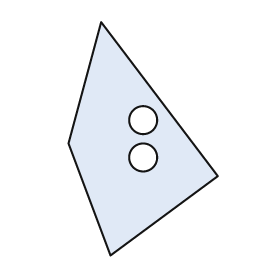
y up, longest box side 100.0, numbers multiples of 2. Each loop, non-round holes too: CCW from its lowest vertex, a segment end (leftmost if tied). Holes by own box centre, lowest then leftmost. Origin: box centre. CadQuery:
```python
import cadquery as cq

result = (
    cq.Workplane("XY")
    .moveTo(-14.0, -50.0)
    .lineTo(32.0, -16.0)
    .lineTo(-18.0, 50.0)
    .lineTo(-32.0, -2.0)
    .close()
    .moveTo(0.0, -8.0)
    .circle(6.0)
    .moveTo(0.0, 8.0)
    .circle(6.0)
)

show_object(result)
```